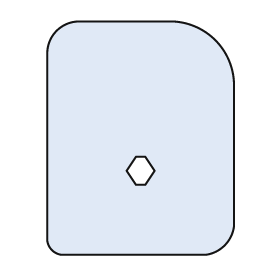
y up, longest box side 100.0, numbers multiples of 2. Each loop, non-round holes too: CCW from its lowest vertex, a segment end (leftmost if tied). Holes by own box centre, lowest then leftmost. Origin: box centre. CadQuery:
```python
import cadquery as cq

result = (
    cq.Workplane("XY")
    .moveTo(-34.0, -50.0)
    .lineTo(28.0, -50.0)
    .threePointArc((36.0, -46.0), (40.0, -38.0))
    .lineTo(40.0, 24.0)
    .threePointArc((32.0, 42.0), (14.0, 50.0))
    .lineTo(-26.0, 50.0)
    .threePointArc((-36.0, 46.0), (-40.0, 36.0))
    .lineTo(-40.0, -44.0)
    .threePointArc((-38.0, -48.0), (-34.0, -50.0))
    .close()
    .moveTo(-2.0, -20.0)
    .lineTo(2.0, -20.0)
    .lineTo(6.0, -14.0)
    .lineTo(2.0, -8.0)
    .lineTo(-2.0, -8.0)
    .lineTo(-6.0, -14.0)
    .close()
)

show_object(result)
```